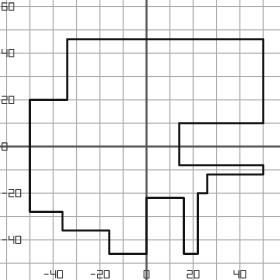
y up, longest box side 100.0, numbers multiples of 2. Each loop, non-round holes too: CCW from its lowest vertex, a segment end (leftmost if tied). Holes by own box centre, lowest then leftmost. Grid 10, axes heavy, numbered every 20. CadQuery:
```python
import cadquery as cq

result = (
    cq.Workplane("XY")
    .moveTo(-16.0, -46.0)
    .lineTo(0.0, -46.0)
    .lineTo(0.0, -22.0)
    .lineTo(16.0, -22.0)
    .lineTo(16.0, -46.0)
    .lineTo(22.0, -46.0)
    .lineTo(22.0, -20.0)
    .lineTo(26.0, -20.0)
    .lineTo(26.0, -12.0)
    .lineTo(50.0, -12.0)
    .lineTo(50.0, -8.0)
    .lineTo(14.0, -8.0)
    .lineTo(14.0, 10.0)
    .lineTo(50.0, 10.0)
    .lineTo(50.0, 46.0)
    .lineTo(-34.0, 46.0)
    .lineTo(-34.0, 20.0)
    .lineTo(-50.0, 20.0)
    .lineTo(-50.0, -28.0)
    .lineTo(-36.0, -28.0)
    .lineTo(-36.0, -36.0)
    .lineTo(-16.0, -36.0)
    .close()
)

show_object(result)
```